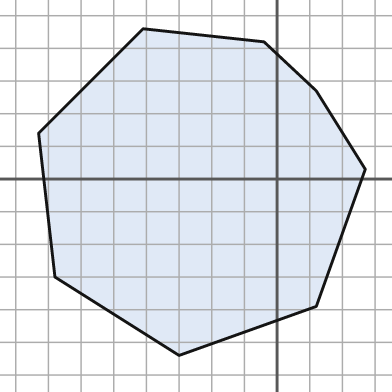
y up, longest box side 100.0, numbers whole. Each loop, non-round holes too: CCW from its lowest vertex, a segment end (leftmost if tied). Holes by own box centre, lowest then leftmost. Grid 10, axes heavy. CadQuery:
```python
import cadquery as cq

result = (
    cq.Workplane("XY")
    .moveTo(-30.0, -54.0)
    .lineTo(12.0, -39.0)
    .lineTo(27.0, 3.0)
    .lineTo(12.0, 27.0)
    .lineTo(-4.0, 42.0)
    .lineTo(-41.0, 46.0)
    .lineTo(-73.0, 14.0)
    .lineTo(-68.0, -30.0)
    .close()
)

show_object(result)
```